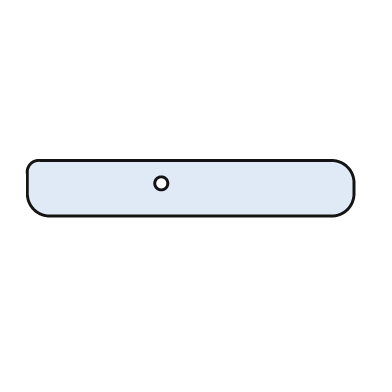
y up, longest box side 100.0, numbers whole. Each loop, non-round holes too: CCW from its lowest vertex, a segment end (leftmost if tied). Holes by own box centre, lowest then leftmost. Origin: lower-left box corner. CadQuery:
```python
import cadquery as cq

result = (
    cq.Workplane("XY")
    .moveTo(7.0, 0.0)
    .lineTo(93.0, 0.0)
    .threePointArc((98.0, 2.0), (100.0, 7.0))
    .lineTo(100.0, 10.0)
    .threePointArc((98.0, 15.0), (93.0, 17.0))
    .lineTo(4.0, 17.0)
    .threePointArc((1.0, 16.0), (0.0, 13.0))
    .lineTo(0.0, 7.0)
    .threePointArc((2.0, 2.0), (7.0, 0.0))
    .close()
    .moveTo(41.0, 10.0)
    .circle(2.0)
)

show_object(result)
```